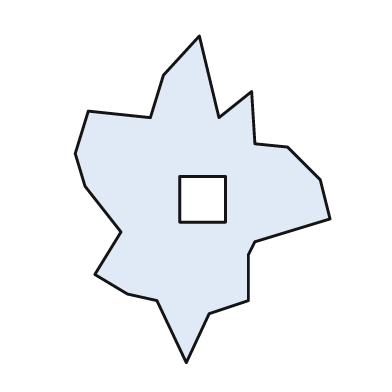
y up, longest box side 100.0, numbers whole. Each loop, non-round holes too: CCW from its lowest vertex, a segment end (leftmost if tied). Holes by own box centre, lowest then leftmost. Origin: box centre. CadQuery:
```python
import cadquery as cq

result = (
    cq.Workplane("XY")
    .moveTo(-5.0, -50.0)
    .lineTo(2.0, -35.0)
    .lineTo(14.0, -31.0)
    .lineTo(14.0, -17.0)
    .lineTo(16.0, -13.0)
    .lineTo(39.0, -6.0)
    .lineTo(36.0, 6.0)
    .lineTo(26.0, 16.0)
    .lineTo(16.0, 17.0)
    .lineTo(15.0, 33.0)
    .lineTo(5.0, 25.0)
    .lineTo(-1.0, 50.0)
    .lineTo(-12.0, 38.0)
    .lineTo(-16.0, 25.0)
    .lineTo(-35.0, 27.0)
    .lineTo(-39.0, 14.0)
    .lineTo(-36.0, 4.0)
    .lineTo(-25.0, -10.0)
    .lineTo(-33.0, -23.0)
    .lineTo(-23.0, -29.0)
    .lineTo(-14.0, -31.0)
    .close()
    .moveTo(-7.0, -7.0)
    .lineTo(7.0, -7.0)
    .lineTo(7.0, 7.0)
    .lineTo(-7.0, 7.0)
    .close()
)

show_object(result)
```